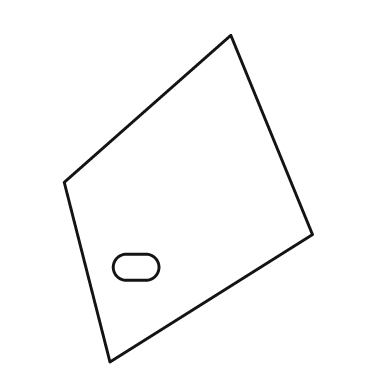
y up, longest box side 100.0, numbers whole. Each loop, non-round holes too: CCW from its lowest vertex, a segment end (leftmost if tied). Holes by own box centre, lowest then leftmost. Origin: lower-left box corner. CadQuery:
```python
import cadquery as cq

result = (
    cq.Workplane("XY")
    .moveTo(14.0, 0.0)
    .lineTo(76.0, 39.0)
    .lineTo(51.0, 100.0)
    .lineTo(0.0, 55.0)
    .close()
    .moveTo(19.0, 25.0)
    .lineTo(25.0, 25.0)
    .threePointArc((29.0, 29.0), (25.0, 33.0))
    .lineTo(19.0, 33.0)
    .threePointArc((15.0, 29.0), (19.0, 25.0))
    .close()
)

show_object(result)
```